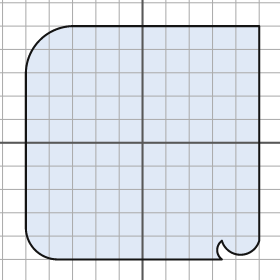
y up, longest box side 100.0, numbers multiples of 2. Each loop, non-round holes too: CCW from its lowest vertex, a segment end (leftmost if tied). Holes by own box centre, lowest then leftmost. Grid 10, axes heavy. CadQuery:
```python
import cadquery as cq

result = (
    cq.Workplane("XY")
    .moveTo(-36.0, -50.0)
    .lineTo(34.0, -50.0)
    .threePointArc((32.0, -46.0), (34.0, -42.0))
    .threePointArc((42.0, -48.0), (50.0, -42.0))
    .lineTo(50.0, 50.0)
    .lineTo(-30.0, 50.0)
    .threePointArc((-44.0, 44.0), (-50.0, 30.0))
    .lineTo(-50.0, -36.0)
    .threePointArc((-46.0, -46.0), (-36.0, -50.0))
    .close()
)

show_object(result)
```